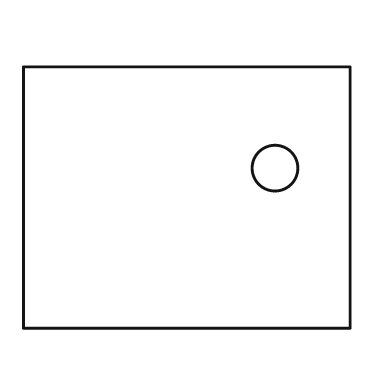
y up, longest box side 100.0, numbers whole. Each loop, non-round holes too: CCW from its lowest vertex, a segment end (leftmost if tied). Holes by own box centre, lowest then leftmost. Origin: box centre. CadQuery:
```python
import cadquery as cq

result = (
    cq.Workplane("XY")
    .moveTo(-50.0, -40.0)
    .lineTo(50.0, -40.0)
    .lineTo(50.0, 40.0)
    .lineTo(-50.0, 40.0)
    .close()
    .moveTo(27.0, 9.0)
    .circle(7.0)
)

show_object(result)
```